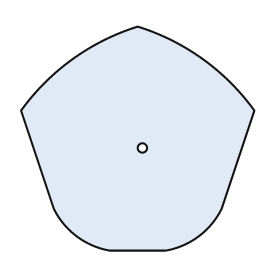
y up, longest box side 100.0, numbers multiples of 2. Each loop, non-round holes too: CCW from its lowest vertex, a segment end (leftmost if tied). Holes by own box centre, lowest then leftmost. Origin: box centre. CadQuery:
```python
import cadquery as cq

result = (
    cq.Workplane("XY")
    .moveTo(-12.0, -48.0)
    .lineTo(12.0, -48.0)
    .threePointArc((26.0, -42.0), (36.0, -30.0))
    .lineTo(50.0, 12.0)
    .threePointArc((28.0, 34.0), (0.0, 48.0))
    .threePointArc((-28.0, 34.0), (-50.0, 12.0))
    .lineTo(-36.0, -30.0)
    .threePointArc((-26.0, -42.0), (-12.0, -48.0))
    .close()
    .moveTo(2.0, -4.0)
    .circle(2.0)
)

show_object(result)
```